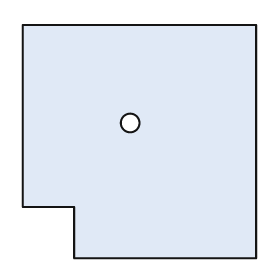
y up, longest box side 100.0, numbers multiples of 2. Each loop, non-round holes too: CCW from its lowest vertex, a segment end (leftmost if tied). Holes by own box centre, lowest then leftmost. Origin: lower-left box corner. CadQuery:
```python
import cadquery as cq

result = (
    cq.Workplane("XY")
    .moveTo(22.0, 0.0)
    .lineTo(100.0, 0.0)
    .lineTo(100.0, 100.0)
    .lineTo(0.0, 100.0)
    .lineTo(0.0, 22.0)
    .lineTo(22.0, 22.0)
    .close()
    .moveTo(46.0, 58.0)
    .circle(4.0)
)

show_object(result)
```